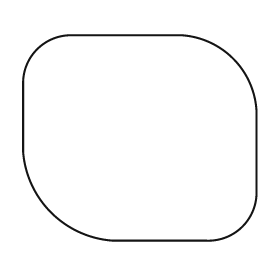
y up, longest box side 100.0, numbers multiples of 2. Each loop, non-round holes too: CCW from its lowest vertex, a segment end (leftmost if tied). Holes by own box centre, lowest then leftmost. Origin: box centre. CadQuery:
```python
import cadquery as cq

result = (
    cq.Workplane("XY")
    .moveTo(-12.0, -44.0)
    .lineTo(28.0, -44.0)
    .threePointArc((44.0, -38.0), (50.0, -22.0))
    .lineTo(50.0, 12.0)
    .threePointArc((40.0, 34.0), (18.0, 44.0))
    .lineTo(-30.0, 44.0)
    .threePointArc((-44.0, 38.0), (-50.0, 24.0))
    .lineTo(-50.0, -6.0)
    .threePointArc((-38.0, -32.0), (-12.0, -44.0))
    .close()
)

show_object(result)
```